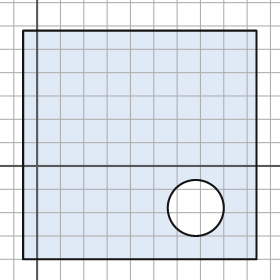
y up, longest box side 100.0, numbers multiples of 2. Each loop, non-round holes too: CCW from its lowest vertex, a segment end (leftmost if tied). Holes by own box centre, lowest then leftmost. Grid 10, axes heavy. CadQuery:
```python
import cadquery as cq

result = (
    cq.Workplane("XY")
    .moveTo(-6.0, -40.0)
    .lineTo(94.0, -40.0)
    .lineTo(94.0, 58.0)
    .lineTo(-6.0, 58.0)
    .close()
    .moveTo(68.0, -18.0)
    .circle(12.0)
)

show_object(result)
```